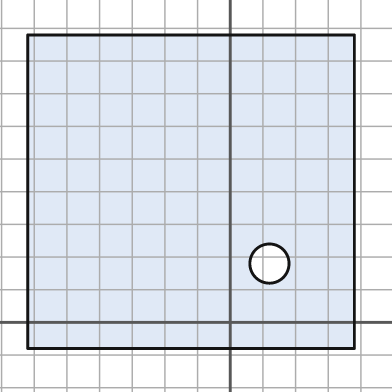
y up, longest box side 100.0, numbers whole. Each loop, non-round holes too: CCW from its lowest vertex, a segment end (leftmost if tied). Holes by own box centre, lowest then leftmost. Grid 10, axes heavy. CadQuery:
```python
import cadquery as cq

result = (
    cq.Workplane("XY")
    .moveTo(-62.0, -8.0)
    .lineTo(38.0, -8.0)
    .lineTo(38.0, 88.0)
    .lineTo(-62.0, 88.0)
    .close()
    .moveTo(12.0, 18.0)
    .circle(6.0)
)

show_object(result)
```